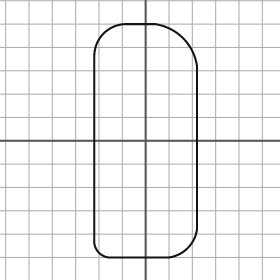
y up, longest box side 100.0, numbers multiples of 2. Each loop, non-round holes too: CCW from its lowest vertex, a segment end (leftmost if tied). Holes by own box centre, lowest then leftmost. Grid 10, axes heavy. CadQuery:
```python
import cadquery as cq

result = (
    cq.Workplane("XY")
    .moveTo(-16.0, -50.0)
    .lineTo(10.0, -50.0)
    .threePointArc((18.0, -46.0), (22.0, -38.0))
    .lineTo(22.0, 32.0)
    .threePointArc((16.0, 44.0), (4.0, 50.0))
    .lineTo(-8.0, 50.0)
    .threePointArc((-18.0, 46.0), (-22.0, 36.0))
    .lineTo(-22.0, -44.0)
    .threePointArc((-20.0, -48.0), (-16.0, -50.0))
    .close()
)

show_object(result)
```